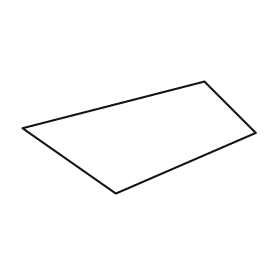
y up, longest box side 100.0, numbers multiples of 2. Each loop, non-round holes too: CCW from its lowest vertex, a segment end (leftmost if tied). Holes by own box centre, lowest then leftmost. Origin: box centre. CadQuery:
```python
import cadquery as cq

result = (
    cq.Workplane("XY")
    .moveTo(-10.0, -24.0)
    .lineTo(50.0, 2.0)
    .lineTo(28.0, 24.0)
    .lineTo(-50.0, 4.0)
    .close()
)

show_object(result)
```